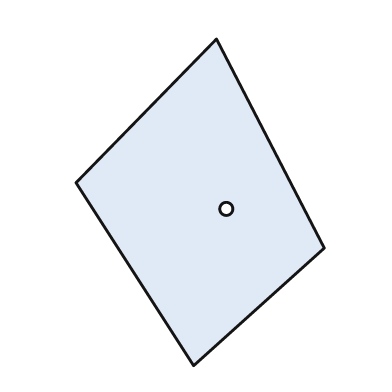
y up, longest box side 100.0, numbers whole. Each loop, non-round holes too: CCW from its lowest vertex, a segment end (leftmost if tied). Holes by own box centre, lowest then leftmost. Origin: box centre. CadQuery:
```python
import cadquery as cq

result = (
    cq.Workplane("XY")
    .moveTo(-2.0, -50.0)
    .lineTo(38.0, -14.0)
    .lineTo(5.0, 50.0)
    .lineTo(-38.0, 6.0)
    .close()
    .moveTo(8.0, -2.0)
    .circle(2.0)
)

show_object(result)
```